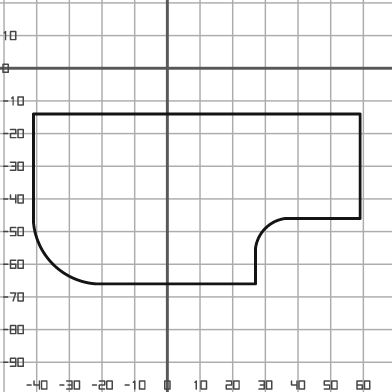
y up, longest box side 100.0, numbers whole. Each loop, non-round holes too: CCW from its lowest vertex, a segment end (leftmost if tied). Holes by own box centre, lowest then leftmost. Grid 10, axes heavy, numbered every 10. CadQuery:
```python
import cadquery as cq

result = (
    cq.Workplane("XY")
    .moveTo(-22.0, -66.0)
    .lineTo(27.0, -66.0)
    .lineTo(27.0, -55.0)
    .threePointArc((30.0, -49.0), (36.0, -46.0))
    .lineTo(59.0, -46.0)
    .lineTo(59.0, -14.0)
    .lineTo(-41.0, -14.0)
    .lineTo(-41.0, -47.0)
    .threePointArc((-35.0, -60.0), (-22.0, -66.0))
    .close()
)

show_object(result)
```